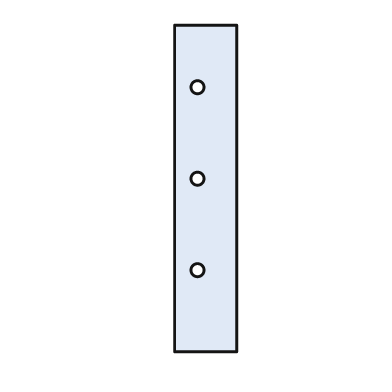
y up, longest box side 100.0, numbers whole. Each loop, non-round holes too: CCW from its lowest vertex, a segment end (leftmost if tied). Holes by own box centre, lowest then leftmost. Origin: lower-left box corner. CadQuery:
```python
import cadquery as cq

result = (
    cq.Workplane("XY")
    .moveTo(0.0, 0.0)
    .lineTo(19.0, 0.0)
    .lineTo(19.0, 100.0)
    .lineTo(0.0, 100.0)
    .close()
    .moveTo(7.0, 25.0)
    .circle(2.0)
    .moveTo(7.0, 53.0)
    .circle(2.0)
    .moveTo(7.0, 81.0)
    .circle(2.0)
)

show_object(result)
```